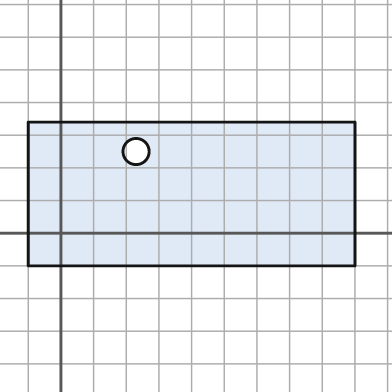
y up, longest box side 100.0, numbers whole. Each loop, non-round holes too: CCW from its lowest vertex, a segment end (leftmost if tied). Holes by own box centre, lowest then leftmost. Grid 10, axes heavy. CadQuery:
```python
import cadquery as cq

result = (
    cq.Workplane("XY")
    .moveTo(-10.0, -10.0)
    .lineTo(90.0, -10.0)
    .lineTo(90.0, 34.0)
    .lineTo(-10.0, 34.0)
    .close()
    .moveTo(23.0, 25.0)
    .circle(4.0)
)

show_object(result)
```